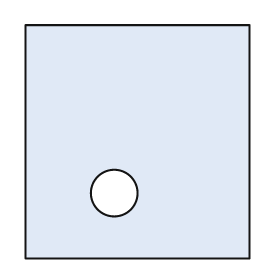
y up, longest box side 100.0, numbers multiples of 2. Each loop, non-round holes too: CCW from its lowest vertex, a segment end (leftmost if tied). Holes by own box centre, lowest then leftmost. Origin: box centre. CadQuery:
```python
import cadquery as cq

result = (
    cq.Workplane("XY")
    .moveTo(-48.0, -50.0)
    .lineTo(48.0, -50.0)
    .lineTo(48.0, 50.0)
    .lineTo(-48.0, 50.0)
    .close()
    .moveTo(-10.0, -22.0)
    .circle(10.0)
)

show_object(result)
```